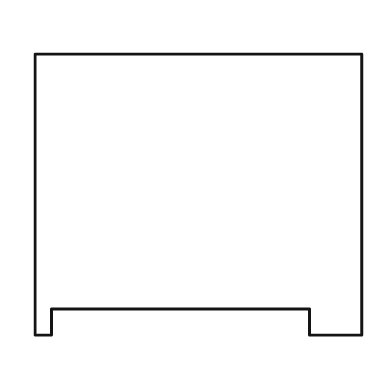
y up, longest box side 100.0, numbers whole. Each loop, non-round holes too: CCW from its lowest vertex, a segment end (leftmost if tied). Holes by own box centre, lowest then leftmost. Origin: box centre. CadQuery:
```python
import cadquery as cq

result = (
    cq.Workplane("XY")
    .moveTo(-50.0, -43.0)
    .lineTo(-45.0, -43.0)
    .lineTo(-45.0, -35.0)
    .lineTo(34.0, -35.0)
    .lineTo(34.0, -43.0)
    .lineTo(50.0, -43.0)
    .lineTo(50.0, 43.0)
    .lineTo(-50.0, 43.0)
    .close()
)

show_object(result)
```